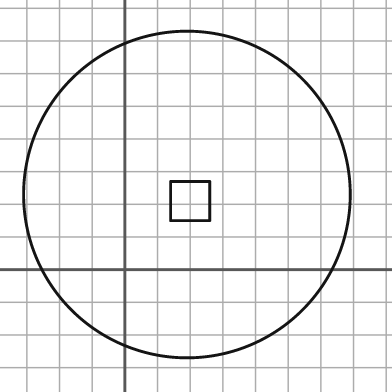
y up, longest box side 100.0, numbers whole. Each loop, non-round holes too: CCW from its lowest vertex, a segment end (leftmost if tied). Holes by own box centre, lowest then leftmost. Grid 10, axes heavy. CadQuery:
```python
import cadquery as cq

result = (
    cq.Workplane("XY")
    .moveTo(19.0, 23.0)
    .circle(50.0)
    .moveTo(14.0, 15.0)
    .lineTo(26.0, 15.0)
    .lineTo(26.0, 27.0)
    .lineTo(14.0, 27.0)
    .close()
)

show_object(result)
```